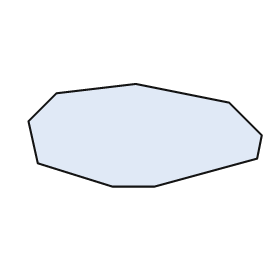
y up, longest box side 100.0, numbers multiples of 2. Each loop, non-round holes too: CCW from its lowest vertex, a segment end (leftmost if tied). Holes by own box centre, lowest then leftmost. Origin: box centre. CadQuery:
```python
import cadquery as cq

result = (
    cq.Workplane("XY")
    .moveTo(-14.0, -22.0)
    .lineTo(4.0, -22.0)
    .lineTo(48.0, -10.0)
    .lineTo(50.0, 0.0)
    .lineTo(36.0, 14.0)
    .lineTo(-4.0, 22.0)
    .lineTo(-38.0, 18.0)
    .lineTo(-50.0, 6.0)
    .lineTo(-46.0, -12.0)
    .close()
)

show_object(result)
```